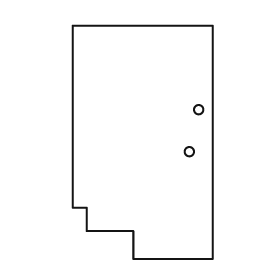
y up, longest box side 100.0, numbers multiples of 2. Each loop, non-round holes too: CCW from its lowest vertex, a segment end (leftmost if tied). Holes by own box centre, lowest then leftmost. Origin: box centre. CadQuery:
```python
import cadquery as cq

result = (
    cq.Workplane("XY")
    .moveTo(-4.0, -50.0)
    .lineTo(30.0, -50.0)
    .lineTo(30.0, 50.0)
    .lineTo(-30.0, 50.0)
    .lineTo(-30.0, -28.0)
    .lineTo(-24.0, -28.0)
    .lineTo(-24.0, -38.0)
    .lineTo(-4.0, -38.0)
    .close()
    .moveTo(20.0, -4.0)
    .circle(2.0)
    .moveTo(24.0, 14.0)
    .circle(2.0)
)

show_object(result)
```